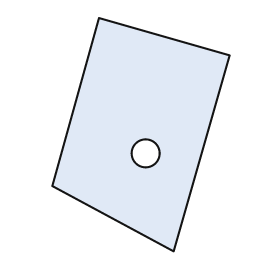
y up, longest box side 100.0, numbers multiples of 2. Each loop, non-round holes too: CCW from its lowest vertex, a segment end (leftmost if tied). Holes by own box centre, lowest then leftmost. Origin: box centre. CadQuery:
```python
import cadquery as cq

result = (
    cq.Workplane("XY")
    .moveTo(14.0, -50.0)
    .lineTo(38.0, 34.0)
    .lineTo(-18.0, 50.0)
    .lineTo(-38.0, -22.0)
    .close()
    .moveTo(2.0, -8.0)
    .circle(6.0)
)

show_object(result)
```